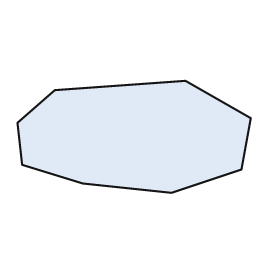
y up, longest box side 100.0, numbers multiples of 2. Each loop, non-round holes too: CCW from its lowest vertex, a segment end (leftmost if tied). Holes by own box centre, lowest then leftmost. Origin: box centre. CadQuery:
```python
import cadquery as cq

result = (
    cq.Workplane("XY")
    .moveTo(16.0, -24.0)
    .lineTo(46.0, -14.0)
    .lineTo(50.0, 8.0)
    .lineTo(22.0, 24.0)
    .lineTo(-34.0, 20.0)
    .lineTo(-50.0, 6.0)
    .lineTo(-48.0, -12.0)
    .lineTo(-22.0, -20.0)
    .close()
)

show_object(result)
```